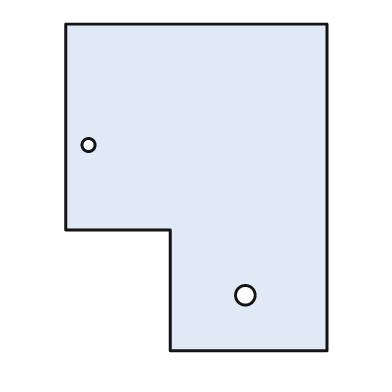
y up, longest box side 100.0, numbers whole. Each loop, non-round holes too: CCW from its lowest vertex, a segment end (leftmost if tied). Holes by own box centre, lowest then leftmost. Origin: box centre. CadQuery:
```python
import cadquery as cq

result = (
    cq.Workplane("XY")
    .moveTo(-8.0, -50.0)
    .lineTo(40.0, -50.0)
    .lineTo(40.0, 50.0)
    .lineTo(-40.0, 50.0)
    .lineTo(-40.0, -13.0)
    .lineTo(-8.0, -13.0)
    .close()
    .moveTo(15.0, -33.0)
    .circle(3.0)
    .moveTo(-33.0, 13.0)
    .circle(2.0)
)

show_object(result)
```